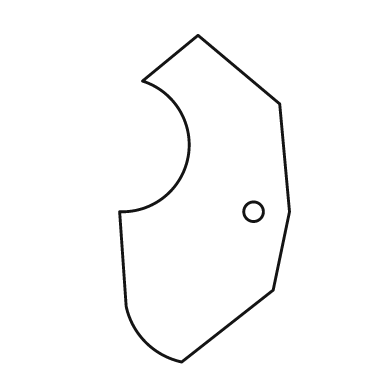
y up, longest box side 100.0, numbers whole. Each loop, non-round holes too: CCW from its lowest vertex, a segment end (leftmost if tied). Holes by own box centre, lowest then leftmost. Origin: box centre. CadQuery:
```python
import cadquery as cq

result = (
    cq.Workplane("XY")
    .moveTo(-7.0, -50.0)
    .lineTo(21.0, -28.0)
    .lineTo(26.0, -4.0)
    .lineTo(23.0, 29.0)
    .lineTo(-2.0, 50.0)
    .lineTo(-19.0, 36.0)
    .threePointArc((-5.0, 13.0), (-26.0, -4.0))
    .lineTo(-24.0, -33.0)
    .threePointArc((-18.0, -44.0), (-7.0, -50.0))
    .close()
    .moveTo(15.0, -4.0)
    .circle(3.0)
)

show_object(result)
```